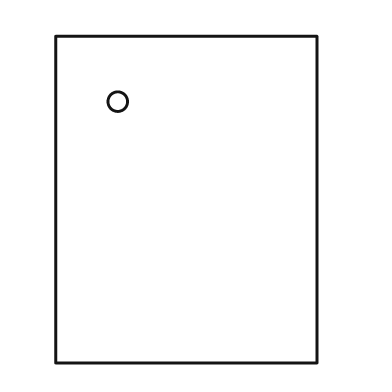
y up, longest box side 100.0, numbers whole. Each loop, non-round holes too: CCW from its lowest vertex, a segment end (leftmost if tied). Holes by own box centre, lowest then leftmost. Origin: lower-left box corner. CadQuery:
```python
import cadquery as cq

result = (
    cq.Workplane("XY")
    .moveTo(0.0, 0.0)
    .lineTo(80.0, 0.0)
    .lineTo(80.0, 100.0)
    .lineTo(0.0, 100.0)
    .close()
    .moveTo(19.0, 80.0)
    .circle(3.0)
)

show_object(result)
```